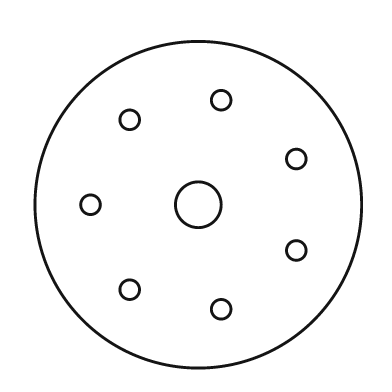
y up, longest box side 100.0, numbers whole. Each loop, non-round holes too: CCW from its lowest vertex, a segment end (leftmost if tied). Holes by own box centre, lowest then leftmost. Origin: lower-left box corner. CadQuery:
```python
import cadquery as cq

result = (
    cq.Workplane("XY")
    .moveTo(50.0, 50.0)
    .circle(50.0)
    .moveTo(57.0, 18.0)
    .circle(3.0)
    .moveTo(29.0, 24.0)
    .circle(3.0)
    .moveTo(80.0, 36.0)
    .circle(3.0)
    .moveTo(17.0, 50.0)
    .circle(3.0)
    .moveTo(50.0, 50.0)
    .circle(7.0)
    .moveTo(80.0, 64.0)
    .circle(3.0)
    .moveTo(29.0, 76.0)
    .circle(3.0)
    .moveTo(57.0, 82.0)
    .circle(3.0)
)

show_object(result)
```